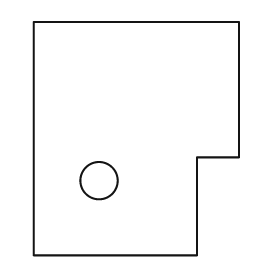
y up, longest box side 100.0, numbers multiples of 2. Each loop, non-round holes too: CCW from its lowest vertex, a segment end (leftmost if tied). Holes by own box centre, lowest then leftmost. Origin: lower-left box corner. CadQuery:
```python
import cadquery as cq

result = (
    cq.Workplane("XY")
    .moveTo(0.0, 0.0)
    .lineTo(70.0, 0.0)
    .lineTo(70.0, 42.0)
    .lineTo(88.0, 42.0)
    .lineTo(88.0, 100.0)
    .lineTo(0.0, 100.0)
    .close()
    .moveTo(28.0, 32.0)
    .circle(8.0)
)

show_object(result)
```